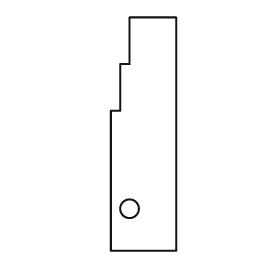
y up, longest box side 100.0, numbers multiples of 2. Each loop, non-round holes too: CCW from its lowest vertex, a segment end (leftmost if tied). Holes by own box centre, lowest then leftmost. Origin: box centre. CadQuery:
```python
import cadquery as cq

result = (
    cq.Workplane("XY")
    .moveTo(-14.0, -50.0)
    .lineTo(14.0, -50.0)
    .lineTo(14.0, 50.0)
    .lineTo(-6.0, 50.0)
    .lineTo(-6.0, 30.0)
    .lineTo(-10.0, 30.0)
    .lineTo(-10.0, 10.0)
    .lineTo(-14.0, 10.0)
    .close()
    .moveTo(-6.0, -32.0)
    .circle(4.0)
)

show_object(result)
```